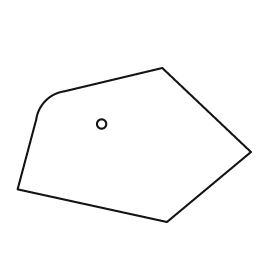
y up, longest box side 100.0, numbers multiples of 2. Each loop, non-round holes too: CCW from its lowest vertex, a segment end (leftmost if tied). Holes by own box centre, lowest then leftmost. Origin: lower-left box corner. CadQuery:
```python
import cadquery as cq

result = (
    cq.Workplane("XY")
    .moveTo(64.0, 0.0)
    .lineTo(100.0, 30.0)
    .lineTo(62.0, 66.0)
    .lineTo(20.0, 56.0)
    .threePointArc((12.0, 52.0), (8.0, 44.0))
    .lineTo(0.0, 14.0)
    .close()
    .moveTo(36.0, 42.0)
    .circle(2.0)
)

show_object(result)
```